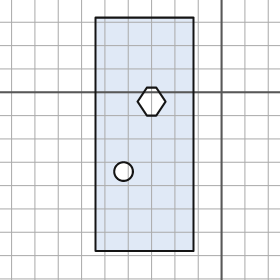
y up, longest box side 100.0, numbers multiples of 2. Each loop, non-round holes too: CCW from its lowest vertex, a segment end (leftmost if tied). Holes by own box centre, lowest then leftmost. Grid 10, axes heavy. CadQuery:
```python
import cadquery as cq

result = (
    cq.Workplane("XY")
    .moveTo(-54.0, -68.0)
    .lineTo(-12.0, -68.0)
    .lineTo(-12.0, 32.0)
    .lineTo(-54.0, 32.0)
    .close()
    .moveTo(-42.0, -34.0)
    .circle(4.0)
    .moveTo(-32.0, -10.0)
    .lineTo(-28.0, -10.0)
    .lineTo(-24.0, -4.0)
    .lineTo(-28.0, 2.0)
    .lineTo(-32.0, 2.0)
    .lineTo(-36.0, -4.0)
    .close()
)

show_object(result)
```